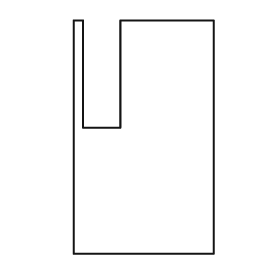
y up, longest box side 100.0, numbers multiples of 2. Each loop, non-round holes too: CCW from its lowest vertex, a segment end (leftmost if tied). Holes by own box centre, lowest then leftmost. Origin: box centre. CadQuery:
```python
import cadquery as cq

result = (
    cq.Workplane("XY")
    .moveTo(-30.0, -50.0)
    .lineTo(30.0, -50.0)
    .lineTo(30.0, 50.0)
    .lineTo(-10.0, 50.0)
    .lineTo(-10.0, 4.0)
    .lineTo(-26.0, 4.0)
    .lineTo(-26.0, 50.0)
    .lineTo(-30.0, 50.0)
    .close()
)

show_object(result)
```